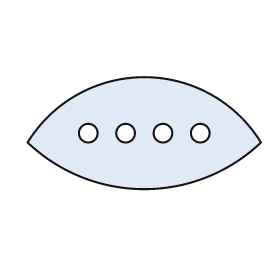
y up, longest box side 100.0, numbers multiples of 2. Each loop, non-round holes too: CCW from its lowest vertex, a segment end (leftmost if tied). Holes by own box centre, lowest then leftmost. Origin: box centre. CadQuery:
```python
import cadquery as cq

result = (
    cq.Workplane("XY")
    .moveTo(-50.0, -4.0)
    .threePointArc((0.0, -24.0), (50.0, -4.0))
    .threePointArc((0.0, 24.0), (-50.0, -4.0))
    .close()
    .moveTo(-24.0, 0.0)
    .circle(4.0)
    .moveTo(-8.0, 0.0)
    .circle(4.0)
    .moveTo(8.0, 0.0)
    .circle(4.0)
    .moveTo(24.0, 0.0)
    .circle(4.0)
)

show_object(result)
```